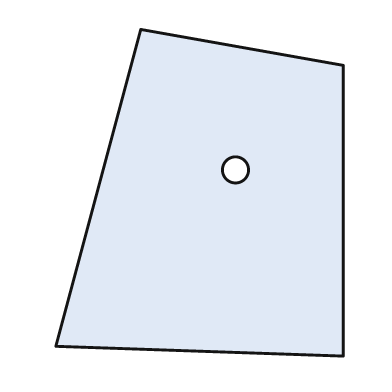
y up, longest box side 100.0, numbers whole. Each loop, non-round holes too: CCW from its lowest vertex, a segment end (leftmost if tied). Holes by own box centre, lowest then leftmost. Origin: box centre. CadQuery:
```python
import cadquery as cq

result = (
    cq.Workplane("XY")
    .moveTo(44.0, -50.0)
    .lineTo(44.0, 39.0)
    .lineTo(-18.0, 50.0)
    .lineTo(-44.0, -47.0)
    .close()
    .moveTo(11.0, 7.0)
    .circle(4.0)
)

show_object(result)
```